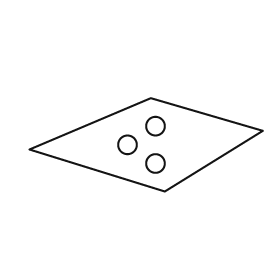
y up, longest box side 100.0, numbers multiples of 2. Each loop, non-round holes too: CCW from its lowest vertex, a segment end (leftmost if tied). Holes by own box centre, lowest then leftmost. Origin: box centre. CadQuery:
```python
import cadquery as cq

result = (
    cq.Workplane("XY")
    .moveTo(8.0, -20.0)
    .lineTo(50.0, 6.0)
    .lineTo(2.0, 20.0)
    .lineTo(-50.0, -2.0)
    .close()
    .moveTo(4.0, -8.0)
    .circle(4.0)
    .moveTo(-8.0, 0.0)
    .circle(4.0)
    .moveTo(4.0, 8.0)
    .circle(4.0)
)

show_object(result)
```